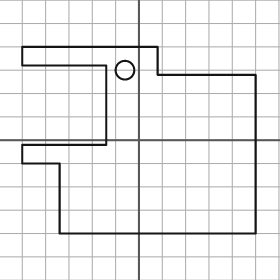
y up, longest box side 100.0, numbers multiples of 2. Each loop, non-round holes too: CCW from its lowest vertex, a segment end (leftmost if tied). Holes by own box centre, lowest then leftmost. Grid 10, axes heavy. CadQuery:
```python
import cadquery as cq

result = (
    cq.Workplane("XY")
    .moveTo(-34.0, -40.0)
    .lineTo(50.0, -40.0)
    .lineTo(50.0, 28.0)
    .lineTo(8.0, 28.0)
    .lineTo(8.0, 40.0)
    .lineTo(-50.0, 40.0)
    .lineTo(-50.0, 32.0)
    .lineTo(-14.0, 32.0)
    .lineTo(-14.0, -2.0)
    .lineTo(-50.0, -2.0)
    .lineTo(-50.0, -10.0)
    .lineTo(-34.0, -10.0)
    .close()
    .moveTo(-6.0, 30.0)
    .circle(4.0)
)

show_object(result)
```